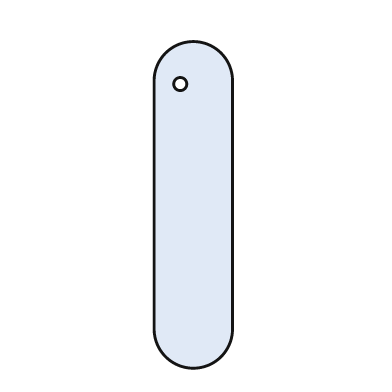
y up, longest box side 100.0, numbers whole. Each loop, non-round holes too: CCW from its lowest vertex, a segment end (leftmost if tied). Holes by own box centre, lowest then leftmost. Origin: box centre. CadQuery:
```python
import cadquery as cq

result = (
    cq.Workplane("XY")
    .moveTo(-12.0, -38.0)
    .threePointArc((0.0, -50.0), (12.0, -38.0))
    .lineTo(12.0, 38.0)
    .threePointArc((0.0, 50.0), (-12.0, 38.0))
    .close()
    .moveTo(-4.0, 37.0)
    .circle(2.0)
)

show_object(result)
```